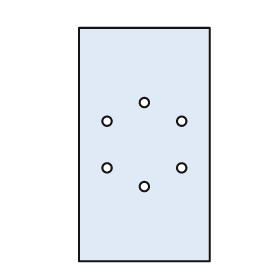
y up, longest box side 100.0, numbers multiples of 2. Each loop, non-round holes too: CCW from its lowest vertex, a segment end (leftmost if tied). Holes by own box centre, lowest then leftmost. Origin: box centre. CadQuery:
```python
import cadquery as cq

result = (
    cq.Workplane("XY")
    .moveTo(-28.0, -50.0)
    .lineTo(28.0, -50.0)
    .lineTo(28.0, 50.0)
    .lineTo(-28.0, 50.0)
    .close()
    .moveTo(0.0, -18.0)
    .circle(2.0)
    .moveTo(-16.0, -10.0)
    .circle(2.0)
    .moveTo(16.0, -10.0)
    .circle(2.0)
    .moveTo(-16.0, 10.0)
    .circle(2.0)
    .moveTo(16.0, 10.0)
    .circle(2.0)
    .moveTo(0.0, 18.0)
    .circle(2.0)
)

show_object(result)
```